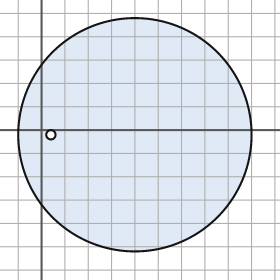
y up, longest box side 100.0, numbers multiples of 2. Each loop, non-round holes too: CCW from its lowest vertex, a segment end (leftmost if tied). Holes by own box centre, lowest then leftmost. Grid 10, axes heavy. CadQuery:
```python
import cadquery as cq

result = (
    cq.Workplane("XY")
    .moveTo(40.0, -2.0)
    .circle(50.0)
    .moveTo(4.0, -2.0)
    .circle(2.0)
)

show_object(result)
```